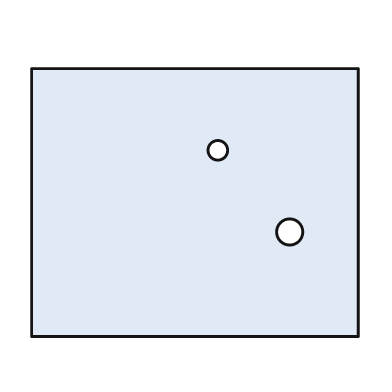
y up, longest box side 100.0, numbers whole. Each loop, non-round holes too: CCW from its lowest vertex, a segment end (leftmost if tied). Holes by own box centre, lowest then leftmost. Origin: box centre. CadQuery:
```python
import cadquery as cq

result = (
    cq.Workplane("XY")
    .moveTo(-50.0, -41.0)
    .lineTo(50.0, -41.0)
    .lineTo(50.0, 41.0)
    .lineTo(-50.0, 41.0)
    .close()
    .moveTo(29.0, -9.0)
    .circle(4.0)
    .moveTo(7.0, 16.0)
    .circle(3.0)
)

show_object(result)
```